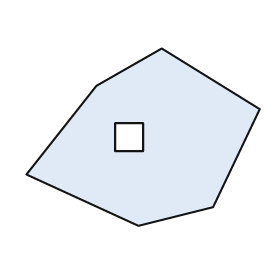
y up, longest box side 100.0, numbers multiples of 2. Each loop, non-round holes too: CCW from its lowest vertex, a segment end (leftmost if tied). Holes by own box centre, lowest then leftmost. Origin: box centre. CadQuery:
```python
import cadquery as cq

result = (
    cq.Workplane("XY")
    .moveTo(-2.0, -38.0)
    .lineTo(30.0, -30.0)
    .lineTo(50.0, 12.0)
    .lineTo(8.0, 38.0)
    .lineTo(-20.0, 22.0)
    .lineTo(-50.0, -16.0)
    .close()
    .moveTo(-12.0, -6.0)
    .lineTo(0.0, -6.0)
    .lineTo(0.0, 6.0)
    .lineTo(-12.0, 6.0)
    .close()
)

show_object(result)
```